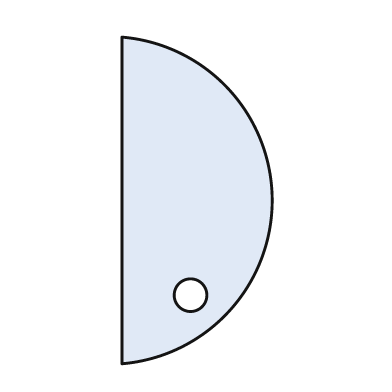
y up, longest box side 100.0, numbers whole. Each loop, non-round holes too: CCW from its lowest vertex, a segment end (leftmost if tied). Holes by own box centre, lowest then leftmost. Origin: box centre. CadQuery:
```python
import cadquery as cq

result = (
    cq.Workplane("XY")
    .moveTo(-23.0, -50.0)
    .threePointArc((23.0, 0.0), (-23.0, 50.0))
    .close()
    .moveTo(-2.0, -29.0)
    .circle(5.0)
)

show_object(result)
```